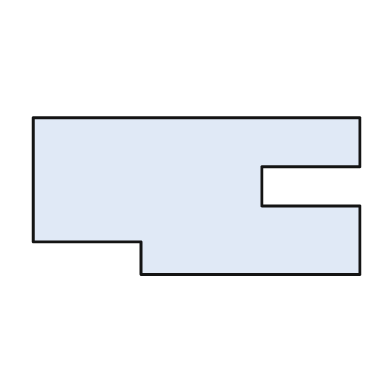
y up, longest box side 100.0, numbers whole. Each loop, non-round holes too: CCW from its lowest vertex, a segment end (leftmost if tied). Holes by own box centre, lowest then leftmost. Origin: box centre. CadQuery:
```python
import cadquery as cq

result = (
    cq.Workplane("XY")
    .moveTo(-17.0, -24.0)
    .lineTo(50.0, -24.0)
    .lineTo(50.0, -3.0)
    .lineTo(20.0, -3.0)
    .lineTo(20.0, 9.0)
    .lineTo(50.0, 9.0)
    .lineTo(50.0, 24.0)
    .lineTo(-50.0, 24.0)
    .lineTo(-50.0, -14.0)
    .lineTo(-17.0, -14.0)
    .close()
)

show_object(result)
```